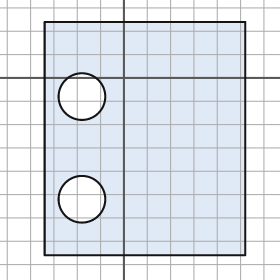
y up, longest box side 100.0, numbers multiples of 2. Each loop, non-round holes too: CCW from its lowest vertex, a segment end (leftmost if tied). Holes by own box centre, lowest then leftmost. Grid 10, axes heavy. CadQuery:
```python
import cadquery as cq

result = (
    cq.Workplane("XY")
    .moveTo(-34.0, -76.0)
    .lineTo(52.0, -76.0)
    .lineTo(52.0, 24.0)
    .lineTo(-34.0, 24.0)
    .close()
    .moveTo(-18.0, -52.0)
    .circle(10.0)
    .moveTo(-18.0, -8.0)
    .circle(10.0)
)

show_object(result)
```